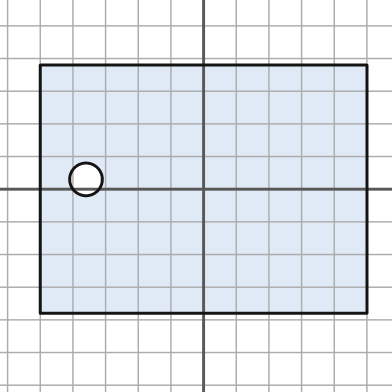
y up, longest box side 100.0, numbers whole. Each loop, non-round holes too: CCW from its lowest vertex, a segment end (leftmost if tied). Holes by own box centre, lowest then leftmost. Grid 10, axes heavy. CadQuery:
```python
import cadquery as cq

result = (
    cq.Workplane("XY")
    .moveTo(-50.0, -38.0)
    .lineTo(50.0, -38.0)
    .lineTo(50.0, 38.0)
    .lineTo(-50.0, 38.0)
    .close()
    .moveTo(-36.0, 3.0)
    .circle(5.0)
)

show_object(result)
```